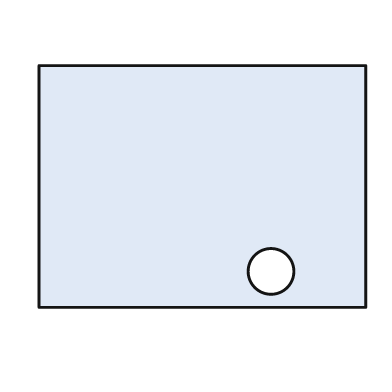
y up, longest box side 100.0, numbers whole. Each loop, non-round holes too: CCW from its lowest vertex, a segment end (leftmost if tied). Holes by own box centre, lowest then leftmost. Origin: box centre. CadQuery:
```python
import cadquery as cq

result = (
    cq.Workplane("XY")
    .moveTo(-50.0, -37.0)
    .lineTo(50.0, -37.0)
    .lineTo(50.0, 37.0)
    .lineTo(-50.0, 37.0)
    .close()
    .moveTo(21.0, -26.0)
    .circle(7.0)
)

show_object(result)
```